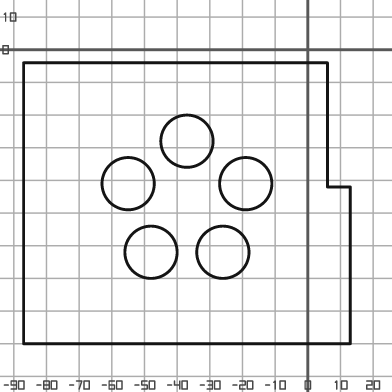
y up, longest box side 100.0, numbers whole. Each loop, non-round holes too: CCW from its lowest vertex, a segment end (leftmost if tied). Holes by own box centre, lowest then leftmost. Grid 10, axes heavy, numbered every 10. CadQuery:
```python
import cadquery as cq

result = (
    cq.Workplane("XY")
    .moveTo(-87.0, -90.0)
    .lineTo(13.0, -90.0)
    .lineTo(13.0, -42.0)
    .lineTo(6.0, -42.0)
    .lineTo(6.0, -4.0)
    .lineTo(-87.0, -4.0)
    .close()
    .moveTo(-48.0, -62.0)
    .circle(8.0)
    .moveTo(-26.0, -62.0)
    .circle(8.0)
    .moveTo(-55.0, -41.0)
    .circle(8.0)
    .moveTo(-19.0, -41.0)
    .circle(8.0)
    .moveTo(-37.0, -28.0)
    .circle(8.0)
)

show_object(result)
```